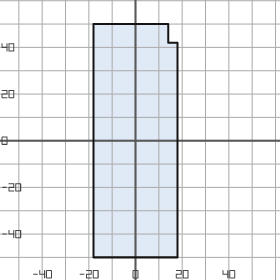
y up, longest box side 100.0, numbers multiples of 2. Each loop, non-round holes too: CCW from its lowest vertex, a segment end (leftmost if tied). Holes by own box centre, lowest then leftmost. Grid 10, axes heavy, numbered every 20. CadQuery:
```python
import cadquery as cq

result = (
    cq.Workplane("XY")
    .moveTo(-18.0, -50.0)
    .lineTo(18.0, -50.0)
    .lineTo(18.0, 42.0)
    .lineTo(14.0, 42.0)
    .lineTo(14.0, 50.0)
    .lineTo(-18.0, 50.0)
    .close()
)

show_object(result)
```